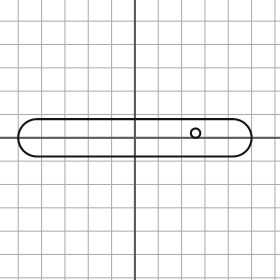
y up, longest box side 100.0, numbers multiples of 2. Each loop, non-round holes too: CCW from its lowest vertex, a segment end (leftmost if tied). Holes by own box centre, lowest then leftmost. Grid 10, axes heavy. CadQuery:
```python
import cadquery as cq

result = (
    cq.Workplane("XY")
    .moveTo(-42.0, -8.0)
    .lineTo(42.0, -8.0)
    .threePointArc((50.0, 0.0), (42.0, 8.0))
    .lineTo(-42.0, 8.0)
    .threePointArc((-50.0, 0.0), (-42.0, -8.0))
    .close()
    .moveTo(26.0, 2.0)
    .circle(2.0)
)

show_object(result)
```